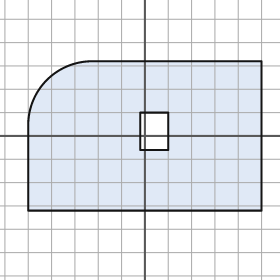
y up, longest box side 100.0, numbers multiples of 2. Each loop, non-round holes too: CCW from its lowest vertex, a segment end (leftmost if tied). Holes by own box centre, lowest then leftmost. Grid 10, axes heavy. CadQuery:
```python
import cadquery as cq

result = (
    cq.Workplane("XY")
    .moveTo(-50.0, -32.0)
    .lineTo(50.0, -32.0)
    .lineTo(50.0, 32.0)
    .lineTo(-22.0, 32.0)
    .threePointArc((-42.0, 24.0), (-50.0, 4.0))
    .close()
    .moveTo(-2.0, -6.0)
    .lineTo(10.0, -6.0)
    .lineTo(10.0, 10.0)
    .lineTo(-2.0, 10.0)
    .close()
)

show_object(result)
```